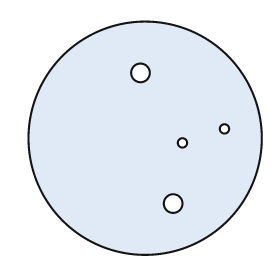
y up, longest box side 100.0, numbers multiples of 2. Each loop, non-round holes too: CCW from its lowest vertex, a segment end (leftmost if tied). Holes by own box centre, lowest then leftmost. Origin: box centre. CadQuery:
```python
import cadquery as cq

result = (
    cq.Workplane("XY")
    .moveTo(0.0, 0.0)
    .circle(50.0)
    .moveTo(12.0, -28.0)
    .circle(4.0)
    .moveTo(16.0, -2.0)
    .circle(2.0)
    .moveTo(34.0, 4.0)
    .circle(2.0)
    .moveTo(-2.0, 28.0)
    .circle(4.0)
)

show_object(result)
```